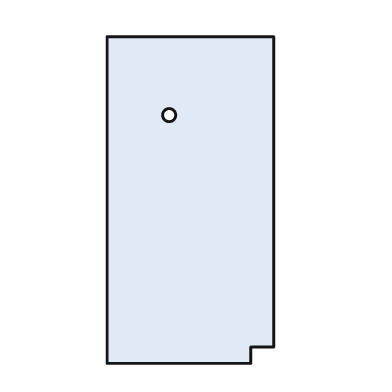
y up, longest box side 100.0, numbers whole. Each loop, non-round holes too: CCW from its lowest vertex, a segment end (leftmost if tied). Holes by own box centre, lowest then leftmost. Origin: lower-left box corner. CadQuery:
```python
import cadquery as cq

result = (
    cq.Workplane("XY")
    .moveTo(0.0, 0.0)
    .lineTo(44.0, 0.0)
    .lineTo(44.0, 5.0)
    .lineTo(51.0, 5.0)
    .lineTo(51.0, 100.0)
    .lineTo(0.0, 100.0)
    .close()
    .moveTo(19.0, 76.0)
    .circle(2.0)
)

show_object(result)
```